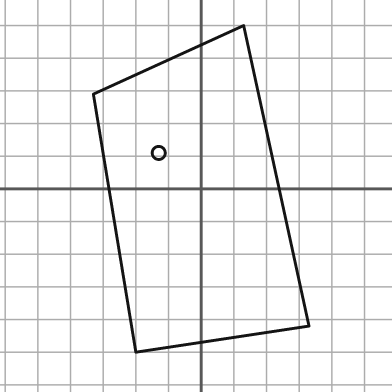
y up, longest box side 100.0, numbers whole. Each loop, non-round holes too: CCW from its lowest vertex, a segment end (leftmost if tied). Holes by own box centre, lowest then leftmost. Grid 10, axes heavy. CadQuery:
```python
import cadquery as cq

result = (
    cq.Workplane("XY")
    .moveTo(-20.0, -50.0)
    .lineTo(33.0, -42.0)
    .lineTo(13.0, 50.0)
    .lineTo(-33.0, 29.0)
    .close()
    .moveTo(-13.0, 11.0)
    .circle(2.0)
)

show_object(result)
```